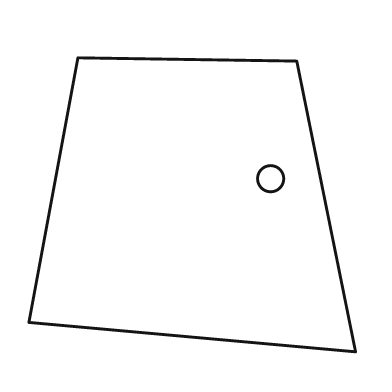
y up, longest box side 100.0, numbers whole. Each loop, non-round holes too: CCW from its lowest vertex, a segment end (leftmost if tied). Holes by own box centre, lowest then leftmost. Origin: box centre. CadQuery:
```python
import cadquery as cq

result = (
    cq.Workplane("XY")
    .moveTo(50.0, -45.0)
    .lineTo(32.0, 44.0)
    .lineTo(-35.0, 45.0)
    .lineTo(-50.0, -36.0)
    .close()
    .moveTo(24.0, 8.0)
    .circle(4.0)
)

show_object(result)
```